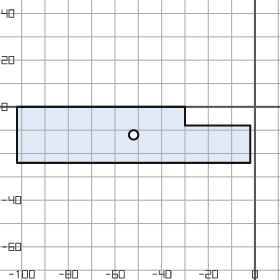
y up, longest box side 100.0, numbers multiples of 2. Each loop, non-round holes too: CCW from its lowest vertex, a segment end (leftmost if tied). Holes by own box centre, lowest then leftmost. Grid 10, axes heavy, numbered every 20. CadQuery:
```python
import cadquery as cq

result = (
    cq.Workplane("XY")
    .moveTo(-102.0, -24.0)
    .lineTo(-2.0, -24.0)
    .lineTo(-2.0, -8.0)
    .lineTo(-30.0, -8.0)
    .lineTo(-30.0, 0.0)
    .lineTo(-102.0, 0.0)
    .close()
    .moveTo(-52.0, -12.0)
    .circle(2.0)
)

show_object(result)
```